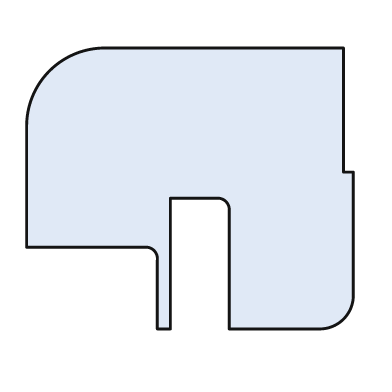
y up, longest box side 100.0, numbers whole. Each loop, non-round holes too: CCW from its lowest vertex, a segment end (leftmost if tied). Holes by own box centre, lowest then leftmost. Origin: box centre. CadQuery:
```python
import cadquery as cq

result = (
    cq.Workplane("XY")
    .moveTo(-10.0, -43.0)
    .lineTo(-6.0, -43.0)
    .lineTo(-6.0, -3.0)
    .lineTo(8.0, -3.0)
    .threePointArc((11.0, -4.0), (12.0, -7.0))
    .lineTo(12.0, -43.0)
    .lineTo(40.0, -43.0)
    .threePointArc((47.0, -40.0), (50.0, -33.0))
    .lineTo(50.0, 5.0)
    .lineTo(47.0, 5.0)
    .lineTo(47.0, 43.0)
    .lineTo(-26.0, 43.0)
    .threePointArc((-43.0, 36.0), (-50.0, 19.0))
    .lineTo(-50.0, -18.0)
    .lineTo(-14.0, -18.0)
    .threePointArc((-11.0, -19.0), (-10.0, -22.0))
    .close()
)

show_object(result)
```